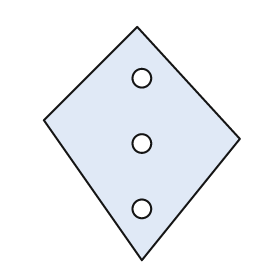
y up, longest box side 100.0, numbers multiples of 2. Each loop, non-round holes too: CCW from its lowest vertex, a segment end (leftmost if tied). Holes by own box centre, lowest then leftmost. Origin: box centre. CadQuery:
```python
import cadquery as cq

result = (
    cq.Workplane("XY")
    .moveTo(0.0, -50.0)
    .lineTo(42.0, 2.0)
    .lineTo(-2.0, 50.0)
    .lineTo(-42.0, 10.0)
    .close()
    .moveTo(0.0, -28.0)
    .circle(4.0)
    .moveTo(0.0, 0.0)
    .circle(4.0)
    .moveTo(0.0, 28.0)
    .circle(4.0)
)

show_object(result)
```